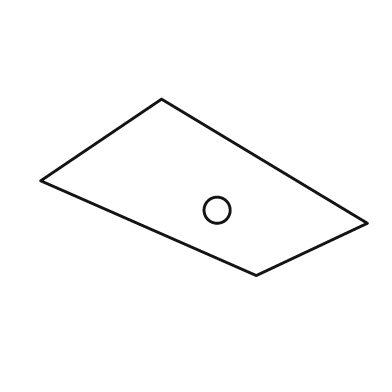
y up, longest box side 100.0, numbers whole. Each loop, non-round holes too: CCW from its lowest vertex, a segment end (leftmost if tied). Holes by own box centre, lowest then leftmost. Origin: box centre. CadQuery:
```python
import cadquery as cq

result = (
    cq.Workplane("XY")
    .moveTo(16.0, -27.0)
    .lineTo(50.0, -11.0)
    .lineTo(-13.0, 27.0)
    .lineTo(-50.0, 2.0)
    .close()
    .moveTo(4.0, -7.0)
    .circle(4.0)
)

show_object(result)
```